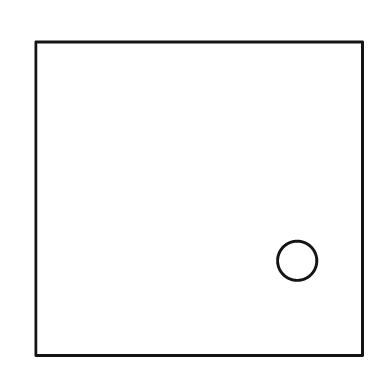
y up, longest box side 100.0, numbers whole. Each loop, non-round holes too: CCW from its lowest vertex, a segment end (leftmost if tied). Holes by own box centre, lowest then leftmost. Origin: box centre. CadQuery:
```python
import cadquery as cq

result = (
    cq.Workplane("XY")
    .moveTo(-50.0, -48.0)
    .lineTo(50.0, -48.0)
    .lineTo(50.0, 48.0)
    .lineTo(-50.0, 48.0)
    .close()
    .moveTo(30.0, -19.0)
    .circle(6.0)
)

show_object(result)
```